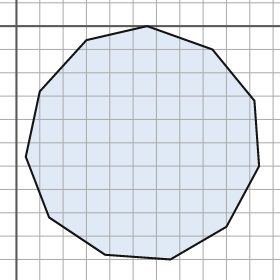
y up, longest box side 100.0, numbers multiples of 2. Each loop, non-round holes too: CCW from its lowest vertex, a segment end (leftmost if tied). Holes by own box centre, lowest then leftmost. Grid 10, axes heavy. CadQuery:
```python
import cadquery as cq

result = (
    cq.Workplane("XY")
    .moveTo(66.0, -100.0)
    .lineTo(90.0, -86.0)
    .lineTo(104.0, -60.0)
    .lineTo(102.0, -32.0)
    .lineTo(84.0, -10.0)
    .lineTo(56.0, 0.0)
    .lineTo(30.0, -6.0)
    .lineTo(10.0, -28.0)
    .lineTo(4.0, -56.0)
    .lineTo(14.0, -82.0)
    .lineTo(38.0, -98.0)
    .close()
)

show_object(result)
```